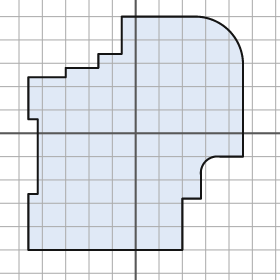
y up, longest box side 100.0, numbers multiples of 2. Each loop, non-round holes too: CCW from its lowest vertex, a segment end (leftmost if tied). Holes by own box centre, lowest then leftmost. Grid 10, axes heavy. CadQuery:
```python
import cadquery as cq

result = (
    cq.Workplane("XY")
    .moveTo(-46.0, -50.0)
    .lineTo(20.0, -50.0)
    .lineTo(20.0, -28.0)
    .lineTo(28.0, -28.0)
    .lineTo(28.0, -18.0)
    .threePointArc((30.0, -12.0), (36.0, -10.0))
    .lineTo(46.0, -10.0)
    .lineTo(46.0, 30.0)
    .threePointArc((40.0, 44.0), (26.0, 50.0))
    .lineTo(-6.0, 50.0)
    .lineTo(-6.0, 34.0)
    .lineTo(-16.0, 34.0)
    .lineTo(-16.0, 28.0)
    .lineTo(-30.0, 28.0)
    .lineTo(-30.0, 24.0)
    .lineTo(-46.0, 24.0)
    .lineTo(-46.0, 6.0)
    .lineTo(-42.0, 6.0)
    .lineTo(-42.0, -26.0)
    .lineTo(-46.0, -26.0)
    .close()
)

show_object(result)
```